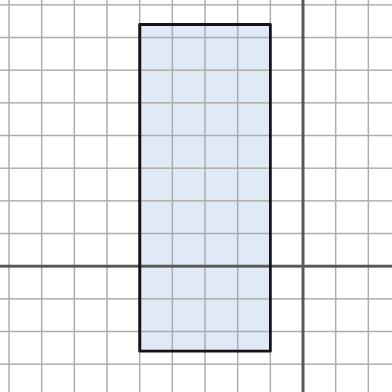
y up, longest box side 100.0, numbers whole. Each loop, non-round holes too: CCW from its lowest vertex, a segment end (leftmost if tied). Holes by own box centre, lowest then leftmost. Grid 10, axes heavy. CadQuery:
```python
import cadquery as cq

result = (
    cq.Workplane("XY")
    .moveTo(-50.0, -26.0)
    .lineTo(-10.0, -26.0)
    .lineTo(-10.0, 74.0)
    .lineTo(-50.0, 74.0)
    .close()
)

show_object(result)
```